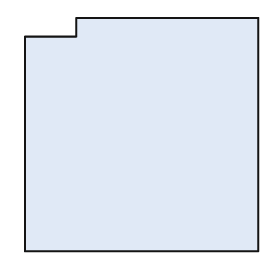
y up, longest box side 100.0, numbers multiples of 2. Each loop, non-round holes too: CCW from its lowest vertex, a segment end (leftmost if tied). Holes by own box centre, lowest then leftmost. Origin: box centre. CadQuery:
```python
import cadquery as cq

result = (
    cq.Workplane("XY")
    .moveTo(-50.0, -50.0)
    .lineTo(50.0, -50.0)
    .lineTo(50.0, 50.0)
    .lineTo(-28.0, 50.0)
    .lineTo(-28.0, 42.0)
    .lineTo(-50.0, 42.0)
    .close()
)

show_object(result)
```